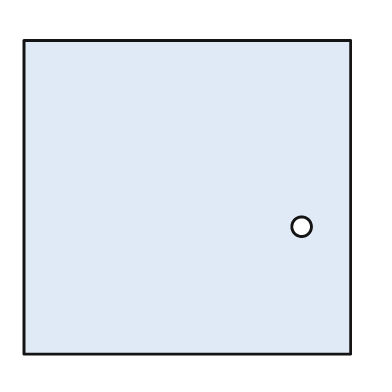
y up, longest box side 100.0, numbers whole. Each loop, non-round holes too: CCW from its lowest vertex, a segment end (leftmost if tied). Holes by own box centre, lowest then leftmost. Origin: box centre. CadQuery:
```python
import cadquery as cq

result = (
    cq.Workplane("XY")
    .moveTo(-50.0, -48.0)
    .lineTo(50.0, -48.0)
    .lineTo(50.0, 48.0)
    .lineTo(-50.0, 48.0)
    .close()
    .moveTo(35.0, -9.0)
    .circle(3.0)
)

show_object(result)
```